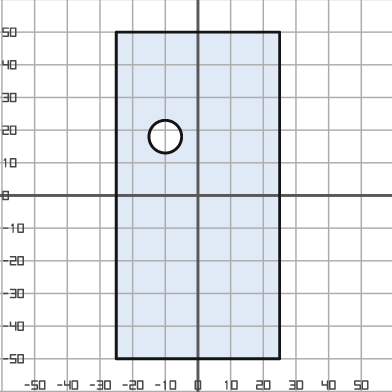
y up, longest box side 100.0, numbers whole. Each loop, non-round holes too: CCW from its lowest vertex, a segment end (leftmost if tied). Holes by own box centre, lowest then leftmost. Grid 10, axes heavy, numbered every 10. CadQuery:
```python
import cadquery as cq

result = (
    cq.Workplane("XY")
    .moveTo(-25.0, -50.0)
    .lineTo(25.0, -50.0)
    .lineTo(25.0, 50.0)
    .lineTo(-25.0, 50.0)
    .close()
    .moveTo(-10.0, 18.0)
    .circle(5.0)
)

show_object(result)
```